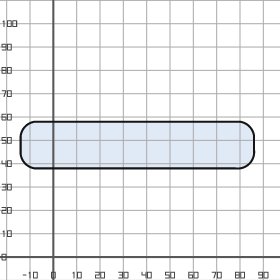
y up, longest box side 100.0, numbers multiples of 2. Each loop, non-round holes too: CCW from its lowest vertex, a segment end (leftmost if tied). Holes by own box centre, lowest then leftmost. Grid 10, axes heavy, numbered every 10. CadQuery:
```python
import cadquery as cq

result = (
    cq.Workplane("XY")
    .moveTo(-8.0, 38.0)
    .lineTo(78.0, 38.0)
    .threePointArc((84.0, 40.0), (86.0, 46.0))
    .lineTo(86.0, 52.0)
    .threePointArc((84.0, 56.0), (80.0, 58.0))
    .lineTo(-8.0, 58.0)
    .threePointArc((-12.0, 56.0), (-14.0, 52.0))
    .lineTo(-14.0, 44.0)
    .threePointArc((-12.0, 40.0), (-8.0, 38.0))
    .close()
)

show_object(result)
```